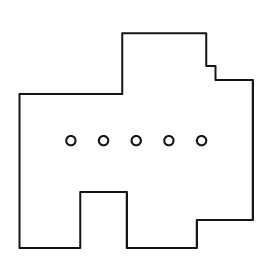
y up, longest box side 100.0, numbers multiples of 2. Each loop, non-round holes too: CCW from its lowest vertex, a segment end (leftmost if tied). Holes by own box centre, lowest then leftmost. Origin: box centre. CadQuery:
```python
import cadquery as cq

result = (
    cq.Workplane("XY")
    .moveTo(-50.0, -46.0)
    .lineTo(-24.0, -46.0)
    .lineTo(-24.0, -22.0)
    .lineTo(-4.0, -22.0)
    .lineTo(-4.0, -46.0)
    .lineTo(26.0, -46.0)
    .lineTo(26.0, -34.0)
    .lineTo(50.0, -34.0)
    .lineTo(50.0, 26.0)
    .lineTo(34.0, 26.0)
    .lineTo(34.0, 32.0)
    .lineTo(30.0, 32.0)
    .lineTo(30.0, 46.0)
    .lineTo(-6.0, 46.0)
    .lineTo(-6.0, 20.0)
    .lineTo(-50.0, 20.0)
    .close()
    .moveTo(-28.0, 0.0)
    .circle(2.0)
    .moveTo(-14.0, 0.0)
    .circle(2.0)
    .moveTo(0.0, 0.0)
    .circle(2.0)
    .moveTo(14.0, 0.0)
    .circle(2.0)
    .moveTo(28.0, 0.0)
    .circle(2.0)
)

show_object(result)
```